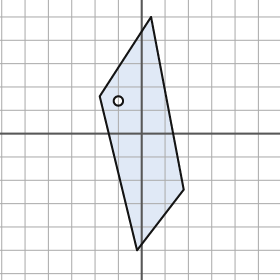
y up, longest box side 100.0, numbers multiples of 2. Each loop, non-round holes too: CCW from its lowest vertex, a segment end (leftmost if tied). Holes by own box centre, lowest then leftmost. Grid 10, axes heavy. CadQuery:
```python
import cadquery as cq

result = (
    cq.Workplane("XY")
    .moveTo(-2.0, -50.0)
    .lineTo(18.0, -24.0)
    .lineTo(4.0, 50.0)
    .lineTo(-18.0, 16.0)
    .close()
    .moveTo(-10.0, 14.0)
    .circle(2.0)
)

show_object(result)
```